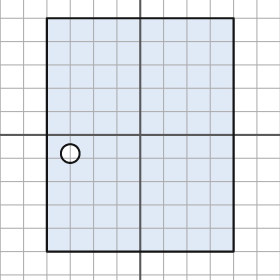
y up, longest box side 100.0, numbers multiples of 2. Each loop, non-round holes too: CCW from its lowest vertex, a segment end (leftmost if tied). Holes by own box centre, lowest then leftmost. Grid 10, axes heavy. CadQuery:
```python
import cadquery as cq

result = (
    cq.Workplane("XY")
    .moveTo(-40.0, -50.0)
    .lineTo(40.0, -50.0)
    .lineTo(40.0, 50.0)
    .lineTo(-40.0, 50.0)
    .close()
    .moveTo(-30.0, -8.0)
    .circle(4.0)
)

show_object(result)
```